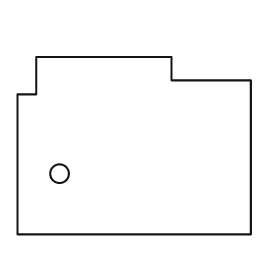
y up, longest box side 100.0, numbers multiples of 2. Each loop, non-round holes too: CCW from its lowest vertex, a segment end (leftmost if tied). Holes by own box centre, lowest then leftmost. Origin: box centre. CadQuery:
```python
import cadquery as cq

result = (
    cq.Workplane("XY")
    .moveTo(-50.0, -38.0)
    .lineTo(50.0, -38.0)
    .lineTo(50.0, 28.0)
    .lineTo(16.0, 28.0)
    .lineTo(16.0, 38.0)
    .lineTo(-42.0, 38.0)
    .lineTo(-42.0, 22.0)
    .lineTo(-50.0, 22.0)
    .close()
    .moveTo(-32.0, -12.0)
    .circle(4.0)
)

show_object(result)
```